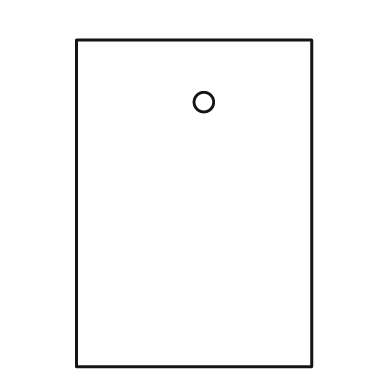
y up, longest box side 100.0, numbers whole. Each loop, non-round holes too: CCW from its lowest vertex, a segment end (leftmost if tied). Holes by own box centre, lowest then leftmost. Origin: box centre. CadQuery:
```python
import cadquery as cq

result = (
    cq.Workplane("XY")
    .moveTo(-36.0, -50.0)
    .lineTo(36.0, -50.0)
    .lineTo(36.0, 50.0)
    .lineTo(-36.0, 50.0)
    .close()
    .moveTo(3.0, 31.0)
    .circle(3.0)
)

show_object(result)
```